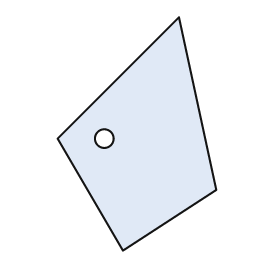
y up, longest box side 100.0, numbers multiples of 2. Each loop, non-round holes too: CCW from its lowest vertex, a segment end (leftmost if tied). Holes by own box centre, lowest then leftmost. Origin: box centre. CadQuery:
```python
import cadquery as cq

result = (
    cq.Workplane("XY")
    .moveTo(-6.0, -50.0)
    .lineTo(34.0, -24.0)
    .lineTo(18.0, 50.0)
    .lineTo(-34.0, -2.0)
    .close()
    .moveTo(-14.0, -2.0)
    .circle(4.0)
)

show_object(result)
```